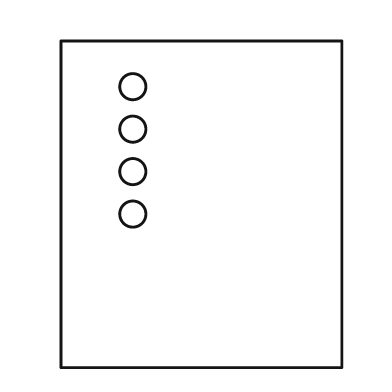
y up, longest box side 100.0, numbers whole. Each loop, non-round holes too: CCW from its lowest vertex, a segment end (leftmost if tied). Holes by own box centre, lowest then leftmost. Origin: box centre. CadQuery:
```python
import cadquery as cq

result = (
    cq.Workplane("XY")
    .moveTo(-43.0, -50.0)
    .lineTo(43.0, -50.0)
    .lineTo(43.0, 50.0)
    .lineTo(-43.0, 50.0)
    .close()
    .moveTo(-21.0, -3.0)
    .circle(4.0)
    .moveTo(-21.0, 10.0)
    .circle(4.0)
    .moveTo(-21.0, 23.0)
    .circle(4.0)
    .moveTo(-21.0, 36.0)
    .circle(4.0)
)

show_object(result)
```